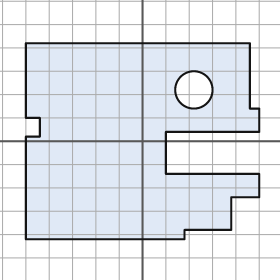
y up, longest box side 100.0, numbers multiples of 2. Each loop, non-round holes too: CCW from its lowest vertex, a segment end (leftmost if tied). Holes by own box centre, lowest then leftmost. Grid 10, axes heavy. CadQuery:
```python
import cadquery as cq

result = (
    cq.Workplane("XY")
    .moveTo(-50.0, -42.0)
    .lineTo(18.0, -42.0)
    .lineTo(18.0, -38.0)
    .lineTo(38.0, -38.0)
    .lineTo(38.0, -24.0)
    .lineTo(50.0, -24.0)
    .lineTo(50.0, -14.0)
    .lineTo(10.0, -14.0)
    .lineTo(10.0, 4.0)
    .lineTo(50.0, 4.0)
    .lineTo(50.0, 14.0)
    .lineTo(46.0, 14.0)
    .lineTo(46.0, 42.0)
    .lineTo(-50.0, 42.0)
    .lineTo(-50.0, 10.0)
    .lineTo(-44.0, 10.0)
    .lineTo(-44.0, 2.0)
    .lineTo(-50.0, 2.0)
    .close()
    .moveTo(22.0, 22.0)
    .circle(8.0)
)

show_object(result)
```